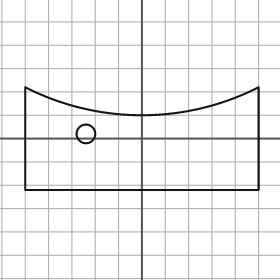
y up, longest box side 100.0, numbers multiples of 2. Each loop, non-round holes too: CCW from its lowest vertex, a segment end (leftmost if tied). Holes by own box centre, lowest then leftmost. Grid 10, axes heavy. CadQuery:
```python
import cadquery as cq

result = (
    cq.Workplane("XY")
    .moveTo(-50.0, -22.0)
    .lineTo(50.0, -22.0)
    .lineTo(50.0, 22.0)
    .threePointArc((0.0, 10.0), (-50.0, 22.0))
    .close()
    .moveTo(-24.0, 2.0)
    .circle(4.0)
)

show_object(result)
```